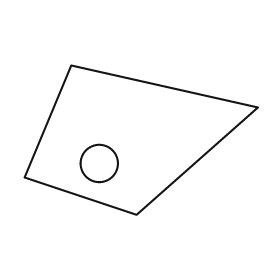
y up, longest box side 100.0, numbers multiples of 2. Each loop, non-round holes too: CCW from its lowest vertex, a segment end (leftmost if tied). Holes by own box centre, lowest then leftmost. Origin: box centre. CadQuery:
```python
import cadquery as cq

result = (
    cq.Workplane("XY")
    .moveTo(-2.0, -32.0)
    .lineTo(50.0, 14.0)
    .lineTo(-30.0, 32.0)
    .lineTo(-50.0, -16.0)
    .close()
    .moveTo(-18.0, -10.0)
    .circle(8.0)
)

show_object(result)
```